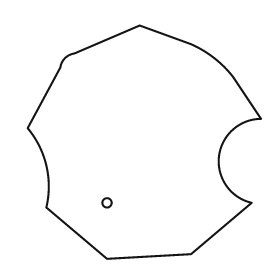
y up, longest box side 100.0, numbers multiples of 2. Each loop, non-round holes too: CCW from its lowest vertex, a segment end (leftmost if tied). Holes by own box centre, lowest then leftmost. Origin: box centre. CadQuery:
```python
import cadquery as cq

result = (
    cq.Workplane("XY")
    .moveTo(-16.0, -50.0)
    .lineTo(20.0, -48.0)
    .lineTo(46.0, -26.0)
    .threePointArc((32.0, -6.0), (50.0, 10.0))
    .lineTo(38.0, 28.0)
    .threePointArc((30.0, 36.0), (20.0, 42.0))
    .lineTo(-2.0, 50.0)
    .lineTo(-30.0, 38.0)
    .threePointArc((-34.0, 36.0), (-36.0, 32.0))
    .lineTo(-50.0, 6.0)
    .threePointArc((-42.0, -10.0), (-42.0, -28.0))
    .close()
    .moveTo(-16.0, -26.0)
    .circle(2.0)
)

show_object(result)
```